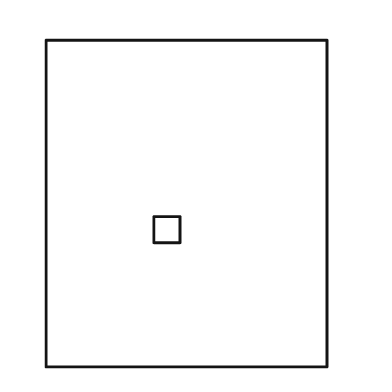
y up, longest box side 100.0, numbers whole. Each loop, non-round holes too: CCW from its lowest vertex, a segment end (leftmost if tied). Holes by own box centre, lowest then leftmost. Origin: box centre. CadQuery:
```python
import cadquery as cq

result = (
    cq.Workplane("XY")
    .moveTo(-43.0, -50.0)
    .lineTo(43.0, -50.0)
    .lineTo(43.0, 50.0)
    .lineTo(-43.0, 50.0)
    .close()
    .moveTo(-10.0, -12.0)
    .lineTo(-2.0, -12.0)
    .lineTo(-2.0, -4.0)
    .lineTo(-10.0, -4.0)
    .close()
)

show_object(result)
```